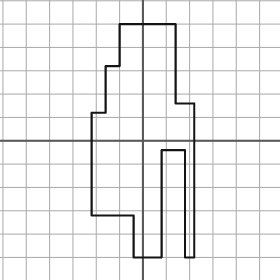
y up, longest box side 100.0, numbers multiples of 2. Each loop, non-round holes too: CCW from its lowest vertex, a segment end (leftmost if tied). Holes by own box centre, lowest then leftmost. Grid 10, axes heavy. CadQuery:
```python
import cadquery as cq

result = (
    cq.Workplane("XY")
    .moveTo(-4.0, -50.0)
    .lineTo(8.0, -50.0)
    .lineTo(8.0, -4.0)
    .lineTo(18.0, -4.0)
    .lineTo(18.0, -50.0)
    .lineTo(22.0, -50.0)
    .lineTo(22.0, 16.0)
    .lineTo(14.0, 16.0)
    .lineTo(14.0, 50.0)
    .lineTo(-10.0, 50.0)
    .lineTo(-10.0, 32.0)
    .lineTo(-16.0, 32.0)
    .lineTo(-16.0, 12.0)
    .lineTo(-22.0, 12.0)
    .lineTo(-22.0, -32.0)
    .lineTo(-4.0, -32.0)
    .close()
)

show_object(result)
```